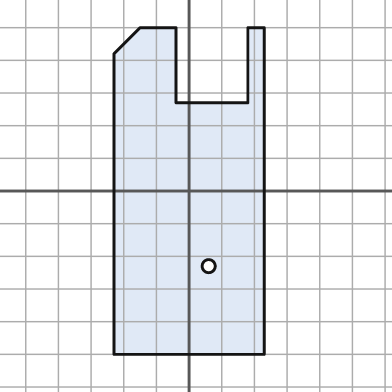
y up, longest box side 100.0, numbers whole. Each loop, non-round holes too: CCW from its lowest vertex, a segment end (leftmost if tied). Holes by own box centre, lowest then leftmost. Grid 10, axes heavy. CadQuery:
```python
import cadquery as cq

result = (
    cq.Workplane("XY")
    .moveTo(-23.0, -50.0)
    .lineTo(23.0, -50.0)
    .lineTo(23.0, 50.0)
    .lineTo(18.0, 50.0)
    .lineTo(18.0, 27.0)
    .lineTo(-4.0, 27.0)
    .lineTo(-4.0, 50.0)
    .lineTo(-15.0, 50.0)
    .lineTo(-23.0, 42.0)
    .close()
    .moveTo(6.0, -23.0)
    .circle(2.0)
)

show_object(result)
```